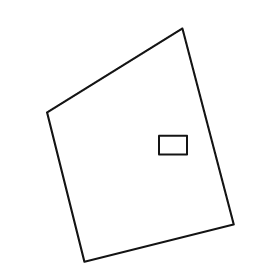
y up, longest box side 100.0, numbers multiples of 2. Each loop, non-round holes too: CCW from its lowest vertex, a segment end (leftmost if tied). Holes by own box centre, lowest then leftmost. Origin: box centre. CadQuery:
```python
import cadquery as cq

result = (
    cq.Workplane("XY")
    .moveTo(-24.0, -50.0)
    .lineTo(40.0, -34.0)
    .lineTo(18.0, 50.0)
    .lineTo(-40.0, 14.0)
    .close()
    .moveTo(8.0, -4.0)
    .lineTo(20.0, -4.0)
    .lineTo(20.0, 4.0)
    .lineTo(8.0, 4.0)
    .close()
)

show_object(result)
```